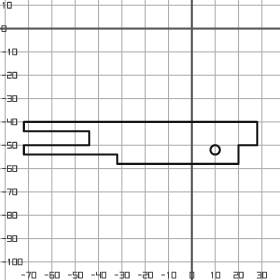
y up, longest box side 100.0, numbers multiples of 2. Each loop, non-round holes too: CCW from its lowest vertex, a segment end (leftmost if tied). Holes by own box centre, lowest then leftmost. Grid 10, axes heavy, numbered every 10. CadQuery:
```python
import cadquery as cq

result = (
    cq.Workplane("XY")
    .moveTo(-32.0, -58.0)
    .lineTo(20.0, -58.0)
    .lineTo(20.0, -50.0)
    .lineTo(28.0, -50.0)
    .lineTo(28.0, -40.0)
    .lineTo(-72.0, -40.0)
    .lineTo(-72.0, -44.0)
    .lineTo(-44.0, -44.0)
    .lineTo(-44.0, -50.0)
    .lineTo(-72.0, -50.0)
    .lineTo(-72.0, -54.0)
    .lineTo(-32.0, -54.0)
    .close()
    .moveTo(10.0, -52.0)
    .circle(2.0)
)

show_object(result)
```